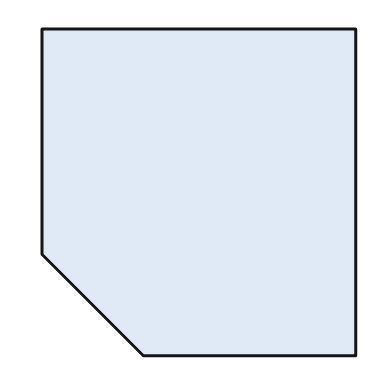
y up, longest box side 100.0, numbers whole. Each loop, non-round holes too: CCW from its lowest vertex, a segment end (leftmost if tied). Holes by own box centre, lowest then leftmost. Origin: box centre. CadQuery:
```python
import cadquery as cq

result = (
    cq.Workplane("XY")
    .moveTo(-17.0, -50.0)
    .lineTo(48.0, -50.0)
    .lineTo(48.0, 50.0)
    .lineTo(-48.0, 50.0)
    .lineTo(-48.0, -19.0)
    .close()
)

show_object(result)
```